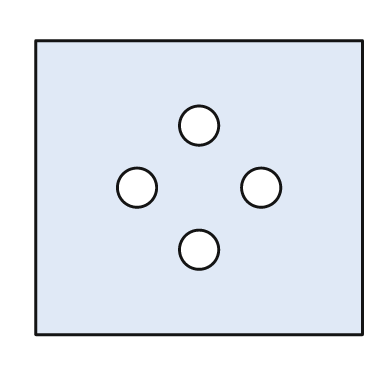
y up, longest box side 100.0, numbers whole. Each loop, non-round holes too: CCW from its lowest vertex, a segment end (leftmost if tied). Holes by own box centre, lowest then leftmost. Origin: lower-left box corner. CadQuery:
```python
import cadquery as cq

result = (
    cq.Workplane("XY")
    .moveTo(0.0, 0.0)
    .lineTo(100.0, 0.0)
    .lineTo(100.0, 90.0)
    .lineTo(0.0, 90.0)
    .close()
    .moveTo(50.0, 26.0)
    .circle(6.0)
    .moveTo(31.0, 45.0)
    .circle(6.0)
    .moveTo(69.0, 45.0)
    .circle(6.0)
    .moveTo(50.0, 64.0)
    .circle(6.0)
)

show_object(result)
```